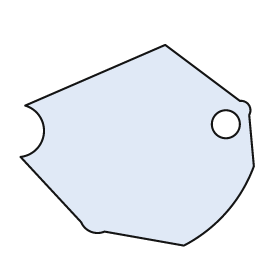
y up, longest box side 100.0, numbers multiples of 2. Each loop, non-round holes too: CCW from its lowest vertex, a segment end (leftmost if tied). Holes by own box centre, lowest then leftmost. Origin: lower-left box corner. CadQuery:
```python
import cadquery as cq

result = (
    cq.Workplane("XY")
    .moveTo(70.0, 0.0)
    .threePointArc((88.0, 14.0), (100.0, 34.0))
    .lineTo(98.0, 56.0)
    .threePointArc((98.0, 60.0), (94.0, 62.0))
    .lineTo(62.0, 86.0)
    .lineTo(2.0, 60.0)
    .threePointArc((10.0, 48.0), (0.0, 38.0))
    .lineTo(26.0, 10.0)
    .threePointArc((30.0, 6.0), (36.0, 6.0))
    .close()
    .moveTo(88.0, 52.0)
    .circle(6.0)
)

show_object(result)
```